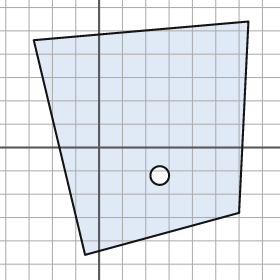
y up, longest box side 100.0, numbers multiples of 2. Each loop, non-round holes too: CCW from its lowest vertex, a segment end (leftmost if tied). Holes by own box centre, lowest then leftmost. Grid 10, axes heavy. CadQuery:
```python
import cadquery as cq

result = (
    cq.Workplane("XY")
    .moveTo(-6.0, -46.0)
    .lineTo(60.0, -28.0)
    .lineTo(64.0, 54.0)
    .lineTo(-28.0, 46.0)
    .close()
    .moveTo(26.0, -12.0)
    .circle(4.0)
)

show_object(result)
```